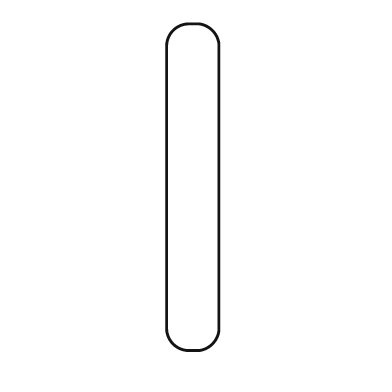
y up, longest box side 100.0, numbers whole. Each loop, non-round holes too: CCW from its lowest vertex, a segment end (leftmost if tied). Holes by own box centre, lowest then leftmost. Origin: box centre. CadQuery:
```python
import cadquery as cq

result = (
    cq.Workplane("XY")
    .moveTo(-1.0, -50.0)
    .lineTo(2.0, -50.0)
    .threePointArc((6.0, -48.0), (8.0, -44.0))
    .lineTo(8.0, 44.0)
    .threePointArc((6.0, 48.0), (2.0, 50.0))
    .lineTo(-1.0, 50.0)
    .threePointArc((-6.0, 48.0), (-8.0, 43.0))
    .lineTo(-8.0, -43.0)
    .threePointArc((-6.0, -48.0), (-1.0, -50.0))
    .close()
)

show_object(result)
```